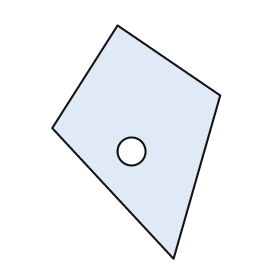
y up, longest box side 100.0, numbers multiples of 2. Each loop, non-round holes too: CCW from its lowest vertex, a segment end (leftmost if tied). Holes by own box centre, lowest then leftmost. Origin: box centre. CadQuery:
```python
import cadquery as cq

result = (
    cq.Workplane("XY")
    .moveTo(16.0, -50.0)
    .lineTo(36.0, 20.0)
    .lineTo(-8.0, 50.0)
    .lineTo(-36.0, 6.0)
    .close()
    .moveTo(-2.0, -4.0)
    .circle(6.0)
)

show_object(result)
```